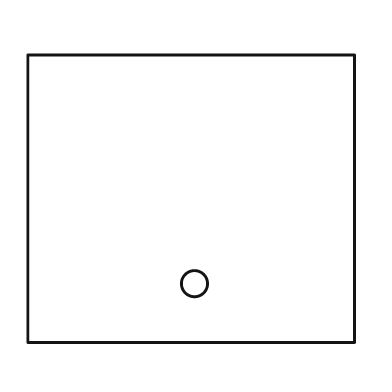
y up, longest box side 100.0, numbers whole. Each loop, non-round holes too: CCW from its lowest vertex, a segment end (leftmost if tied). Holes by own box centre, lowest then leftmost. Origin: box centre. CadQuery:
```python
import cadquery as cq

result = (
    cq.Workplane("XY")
    .moveTo(-50.0, -44.0)
    .lineTo(50.0, -44.0)
    .lineTo(50.0, 44.0)
    .lineTo(-50.0, 44.0)
    .close()
    .moveTo(1.0, -26.0)
    .circle(4.0)
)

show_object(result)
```